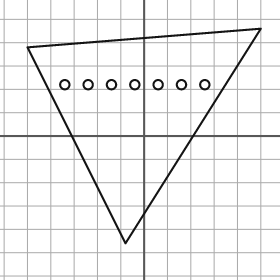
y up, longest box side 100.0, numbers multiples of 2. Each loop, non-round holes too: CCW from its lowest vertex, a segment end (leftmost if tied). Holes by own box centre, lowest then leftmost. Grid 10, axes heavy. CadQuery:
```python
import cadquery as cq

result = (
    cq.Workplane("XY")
    .moveTo(-8.0, -46.0)
    .lineTo(50.0, 46.0)
    .lineTo(-50.0, 38.0)
    .close()
    .moveTo(-34.0, 22.0)
    .circle(2.0)
    .moveTo(-24.0, 22.0)
    .circle(2.0)
    .moveTo(-14.0, 22.0)
    .circle(2.0)
    .moveTo(-4.0, 22.0)
    .circle(2.0)
    .moveTo(6.0, 22.0)
    .circle(2.0)
    .moveTo(16.0, 22.0)
    .circle(2.0)
    .moveTo(26.0, 22.0)
    .circle(2.0)
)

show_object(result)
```